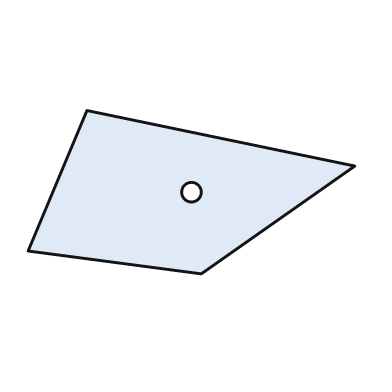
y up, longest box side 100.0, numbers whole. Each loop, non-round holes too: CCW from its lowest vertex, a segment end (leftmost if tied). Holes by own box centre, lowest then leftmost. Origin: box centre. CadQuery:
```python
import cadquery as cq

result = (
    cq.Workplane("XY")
    .moveTo(3.0, -25.0)
    .lineTo(50.0, 8.0)
    .lineTo(-32.0, 25.0)
    .lineTo(-50.0, -18.0)
    .close()
    .moveTo(0.0, 0.0)
    .circle(3.0)
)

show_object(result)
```